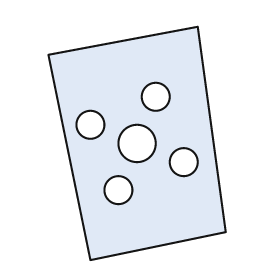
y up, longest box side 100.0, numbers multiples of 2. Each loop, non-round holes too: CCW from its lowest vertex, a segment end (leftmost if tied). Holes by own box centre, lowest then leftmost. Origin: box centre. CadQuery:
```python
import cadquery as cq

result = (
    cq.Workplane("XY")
    .moveTo(-20.0, -50.0)
    .lineTo(38.0, -38.0)
    .lineTo(26.0, 50.0)
    .lineTo(-38.0, 38.0)
    .close()
    .moveTo(-8.0, -20.0)
    .circle(6.0)
    .moveTo(20.0, -8.0)
    .circle(6.0)
    .moveTo(0.0, 0.0)
    .circle(8.0)
    .moveTo(-20.0, 8.0)
    .circle(6.0)
    .moveTo(8.0, 20.0)
    .circle(6.0)
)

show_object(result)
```